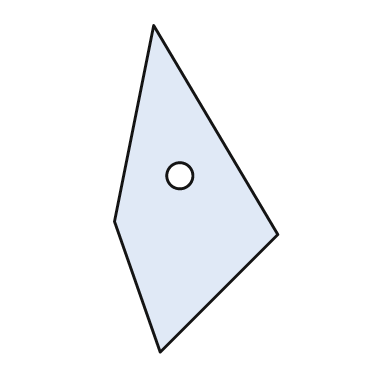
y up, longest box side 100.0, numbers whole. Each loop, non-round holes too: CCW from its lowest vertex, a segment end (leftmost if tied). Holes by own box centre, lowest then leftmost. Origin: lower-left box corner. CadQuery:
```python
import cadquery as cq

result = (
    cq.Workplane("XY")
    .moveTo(14.0, 0.0)
    .lineTo(50.0, 36.0)
    .lineTo(12.0, 100.0)
    .lineTo(0.0, 40.0)
    .close()
    .moveTo(20.0, 54.0)
    .circle(4.0)
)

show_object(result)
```